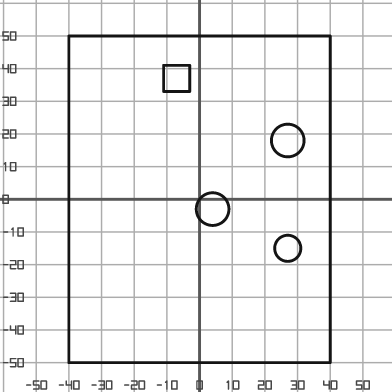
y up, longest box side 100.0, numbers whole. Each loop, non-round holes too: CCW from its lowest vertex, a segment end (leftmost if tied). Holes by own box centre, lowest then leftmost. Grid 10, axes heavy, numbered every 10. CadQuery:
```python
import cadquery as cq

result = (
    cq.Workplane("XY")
    .moveTo(-40.0, -50.0)
    .lineTo(40.0, -50.0)
    .lineTo(40.0, 50.0)
    .lineTo(-40.0, 50.0)
    .close()
    .moveTo(27.0, -15.0)
    .circle(4.0)
    .moveTo(4.0, -3.0)
    .circle(5.0)
    .moveTo(27.0, 18.0)
    .circle(5.0)
    .moveTo(-11.0, 33.0)
    .lineTo(-3.0, 33.0)
    .lineTo(-3.0, 41.0)
    .lineTo(-11.0, 41.0)
    .close()
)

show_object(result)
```